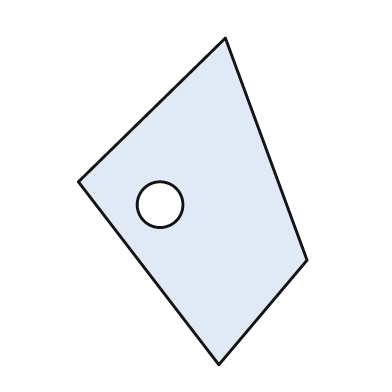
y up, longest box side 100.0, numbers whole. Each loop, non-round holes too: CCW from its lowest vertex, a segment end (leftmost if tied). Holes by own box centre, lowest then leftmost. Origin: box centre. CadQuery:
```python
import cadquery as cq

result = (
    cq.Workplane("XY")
    .moveTo(8.0, -50.0)
    .lineTo(35.0, -18.0)
    .lineTo(10.0, 50.0)
    .lineTo(-35.0, 6.0)
    .close()
    .moveTo(-10.0, -1.0)
    .circle(7.0)
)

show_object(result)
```